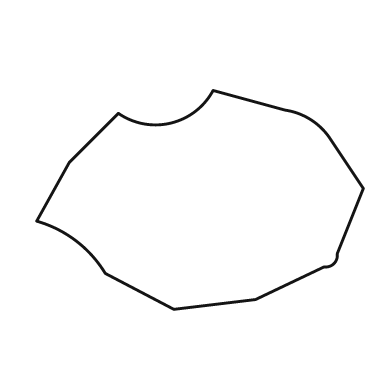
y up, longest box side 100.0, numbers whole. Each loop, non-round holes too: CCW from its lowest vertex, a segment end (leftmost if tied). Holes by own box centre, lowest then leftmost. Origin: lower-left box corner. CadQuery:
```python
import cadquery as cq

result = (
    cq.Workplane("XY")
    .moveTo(42.0, 0.0)
    .lineTo(67.0, 3.0)
    .lineTo(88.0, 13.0)
    .threePointArc((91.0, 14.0), (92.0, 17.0))
    .lineTo(100.0, 37.0)
    .lineTo(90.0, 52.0)
    .threePointArc((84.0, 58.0), (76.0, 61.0))
    .lineTo(54.0, 67.0)
    .threePointArc((41.0, 57.0), (25.0, 60.0))
    .lineTo(10.0, 45.0)
    .lineTo(0.0, 27.0)
    .threePointArc((12.0, 21.0), (21.0, 11.0))
    .close()
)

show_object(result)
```